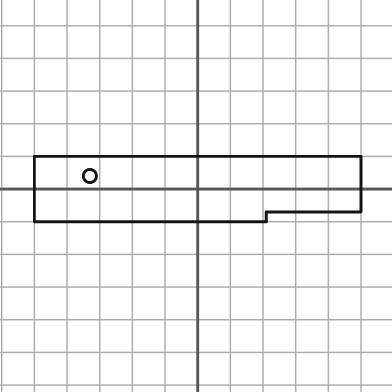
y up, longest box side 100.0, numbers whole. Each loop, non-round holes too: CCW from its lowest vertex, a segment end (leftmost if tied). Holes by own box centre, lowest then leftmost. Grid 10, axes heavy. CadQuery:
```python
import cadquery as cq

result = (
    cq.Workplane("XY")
    .moveTo(-50.0, -10.0)
    .lineTo(21.0, -10.0)
    .lineTo(21.0, -7.0)
    .lineTo(50.0, -7.0)
    .lineTo(50.0, 10.0)
    .lineTo(-50.0, 10.0)
    .close()
    .moveTo(-33.0, 4.0)
    .circle(2.0)
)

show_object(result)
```